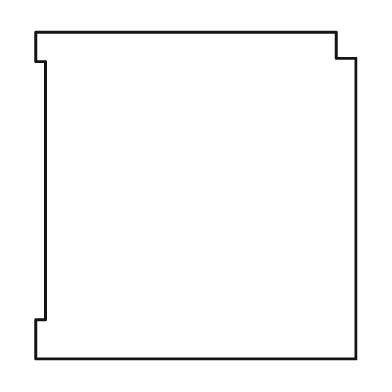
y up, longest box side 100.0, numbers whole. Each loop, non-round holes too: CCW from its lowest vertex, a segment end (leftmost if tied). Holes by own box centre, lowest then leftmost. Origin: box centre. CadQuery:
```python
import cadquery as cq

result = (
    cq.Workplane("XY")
    .moveTo(-49.0, -50.0)
    .lineTo(49.0, -50.0)
    .lineTo(49.0, 42.0)
    .lineTo(43.0, 42.0)
    .lineTo(43.0, 50.0)
    .lineTo(-49.0, 50.0)
    .lineTo(-49.0, 41.0)
    .lineTo(-46.0, 41.0)
    .lineTo(-46.0, -38.0)
    .lineTo(-49.0, -38.0)
    .close()
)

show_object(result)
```